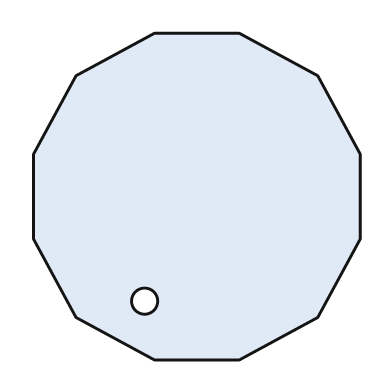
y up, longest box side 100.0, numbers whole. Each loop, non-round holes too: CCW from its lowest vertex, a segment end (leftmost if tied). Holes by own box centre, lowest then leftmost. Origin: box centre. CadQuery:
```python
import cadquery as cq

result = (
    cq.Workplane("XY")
    .moveTo(-13.0, -50.0)
    .lineTo(13.0, -50.0)
    .lineTo(37.0, -37.0)
    .lineTo(50.0, -13.0)
    .lineTo(50.0, 13.0)
    .lineTo(37.0, 37.0)
    .lineTo(13.0, 50.0)
    .lineTo(-13.0, 50.0)
    .lineTo(-37.0, 37.0)
    .lineTo(-50.0, 13.0)
    .lineTo(-50.0, -13.0)
    .lineTo(-37.0, -37.0)
    .close()
    .moveTo(-16.0, -32.0)
    .circle(4.0)
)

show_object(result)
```